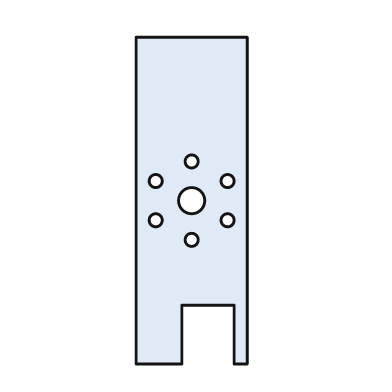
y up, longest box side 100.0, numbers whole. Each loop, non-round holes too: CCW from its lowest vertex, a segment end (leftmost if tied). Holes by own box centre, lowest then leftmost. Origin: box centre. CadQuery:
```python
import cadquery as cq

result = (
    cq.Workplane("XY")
    .moveTo(-17.0, -50.0)
    .lineTo(-3.0, -50.0)
    .lineTo(-3.0, -32.0)
    .lineTo(13.0, -32.0)
    .lineTo(13.0, -50.0)
    .lineTo(17.0, -50.0)
    .lineTo(17.0, 50.0)
    .lineTo(-17.0, 50.0)
    .close()
    .moveTo(0.0, -12.0)
    .circle(2.0)
    .moveTo(-11.0, -6.0)
    .circle(2.0)
    .moveTo(11.0, -6.0)
    .circle(2.0)
    .moveTo(0.0, 0.0)
    .circle(4.0)
    .moveTo(-11.0, 6.0)
    .circle(2.0)
    .moveTo(11.0, 6.0)
    .circle(2.0)
    .moveTo(0.0, 12.0)
    .circle(2.0)
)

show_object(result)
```